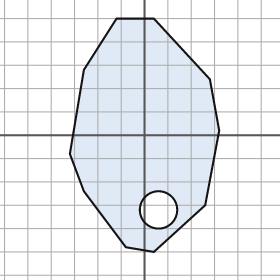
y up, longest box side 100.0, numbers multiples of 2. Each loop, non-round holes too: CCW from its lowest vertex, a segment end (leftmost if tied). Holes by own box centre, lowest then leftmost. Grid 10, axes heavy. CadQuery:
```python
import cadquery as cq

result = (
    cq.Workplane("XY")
    .moveTo(4.0, -50.0)
    .lineTo(26.0, -30.0)
    .lineTo(32.0, 2.0)
    .lineTo(28.0, 24.0)
    .lineTo(4.0, 50.0)
    .lineTo(-12.0, 50.0)
    .lineTo(-26.0, 28.0)
    .lineTo(-32.0, -8.0)
    .lineTo(-26.0, -24.0)
    .lineTo(-8.0, -48.0)
    .close()
    .moveTo(6.0, -32.0)
    .circle(8.0)
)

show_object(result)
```